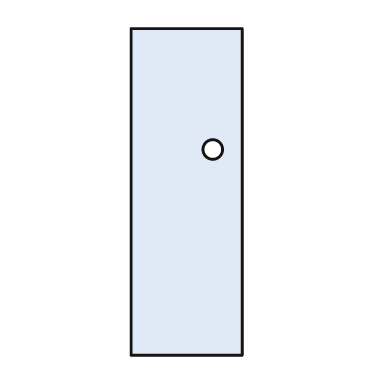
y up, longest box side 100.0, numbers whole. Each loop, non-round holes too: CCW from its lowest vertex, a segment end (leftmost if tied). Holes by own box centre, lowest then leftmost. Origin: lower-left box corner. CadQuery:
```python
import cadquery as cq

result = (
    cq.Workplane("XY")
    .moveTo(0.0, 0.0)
    .lineTo(34.0, 0.0)
    .lineTo(34.0, 100.0)
    .lineTo(0.0, 100.0)
    .close()
    .moveTo(25.0, 63.0)
    .circle(3.0)
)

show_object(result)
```